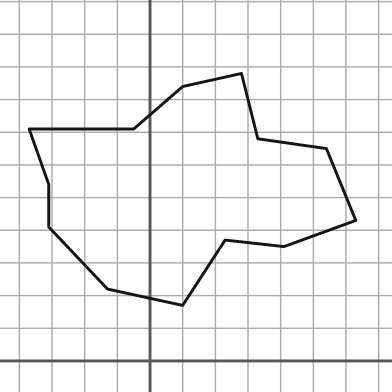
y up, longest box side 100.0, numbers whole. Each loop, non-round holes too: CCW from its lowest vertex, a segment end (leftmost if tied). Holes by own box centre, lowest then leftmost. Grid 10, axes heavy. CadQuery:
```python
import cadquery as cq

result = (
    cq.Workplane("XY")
    .moveTo(10.0, 17.0)
    .lineTo(23.0, 37.0)
    .lineTo(41.0, 35.0)
    .lineTo(63.0, 43.0)
    .lineTo(54.0, 65.0)
    .lineTo(33.0, 68.0)
    .lineTo(28.0, 88.0)
    .lineTo(10.0, 84.0)
    .lineTo(-5.0, 71.0)
    .lineTo(-37.0, 71.0)
    .lineTo(-31.0, 54.0)
    .lineTo(-31.0, 41.0)
    .lineTo(-13.0, 22.0)
    .close()
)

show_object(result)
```